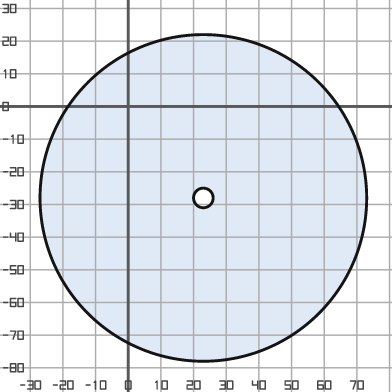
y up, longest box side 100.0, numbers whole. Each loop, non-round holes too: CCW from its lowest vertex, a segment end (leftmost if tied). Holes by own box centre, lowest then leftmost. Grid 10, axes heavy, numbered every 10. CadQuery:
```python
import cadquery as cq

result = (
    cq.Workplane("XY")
    .moveTo(23.0, -28.0)
    .circle(50.0)
    .moveTo(23.0, -28.0)
    .circle(3.0)
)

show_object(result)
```